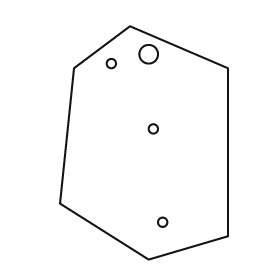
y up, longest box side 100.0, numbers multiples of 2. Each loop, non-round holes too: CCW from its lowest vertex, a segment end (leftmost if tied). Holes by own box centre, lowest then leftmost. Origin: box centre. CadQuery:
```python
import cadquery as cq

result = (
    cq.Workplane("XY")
    .moveTo(2.0, -50.0)
    .lineTo(36.0, -40.0)
    .lineTo(36.0, 32.0)
    .lineTo(-6.0, 50.0)
    .lineTo(-30.0, 32.0)
    .lineTo(-36.0, -26.0)
    .close()
    .moveTo(8.0, -34.0)
    .circle(2.0)
    .moveTo(4.0, 6.0)
    .circle(2.0)
    .moveTo(-14.0, 34.0)
    .circle(2.0)
    .moveTo(2.0, 38.0)
    .circle(4.0)
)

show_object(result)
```